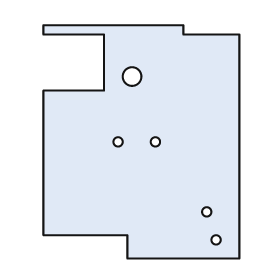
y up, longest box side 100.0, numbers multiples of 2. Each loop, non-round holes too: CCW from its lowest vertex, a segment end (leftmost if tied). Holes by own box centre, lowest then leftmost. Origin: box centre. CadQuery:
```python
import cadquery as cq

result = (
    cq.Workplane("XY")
    .moveTo(-6.0, -50.0)
    .lineTo(42.0, -50.0)
    .lineTo(42.0, 46.0)
    .lineTo(18.0, 46.0)
    .lineTo(18.0, 50.0)
    .lineTo(-42.0, 50.0)
    .lineTo(-42.0, 46.0)
    .lineTo(-16.0, 46.0)
    .lineTo(-16.0, 22.0)
    .lineTo(-42.0, 22.0)
    .lineTo(-42.0, -40.0)
    .lineTo(-6.0, -40.0)
    .close()
    .moveTo(32.0, -42.0)
    .circle(2.0)
    .moveTo(28.0, -30.0)
    .circle(2.0)
    .moveTo(-10.0, 0.0)
    .circle(2.0)
    .moveTo(6.0, 0.0)
    .circle(2.0)
    .moveTo(-4.0, 28.0)
    .circle(4.0)
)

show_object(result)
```